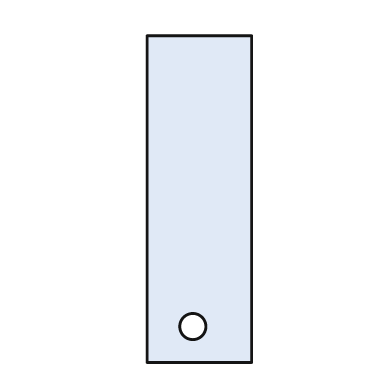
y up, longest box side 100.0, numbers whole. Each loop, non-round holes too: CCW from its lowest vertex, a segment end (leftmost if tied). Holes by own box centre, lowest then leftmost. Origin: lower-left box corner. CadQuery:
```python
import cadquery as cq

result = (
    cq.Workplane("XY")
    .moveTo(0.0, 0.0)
    .lineTo(32.0, 0.0)
    .lineTo(32.0, 100.0)
    .lineTo(0.0, 100.0)
    .close()
    .moveTo(14.0, 11.0)
    .circle(4.0)
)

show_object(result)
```